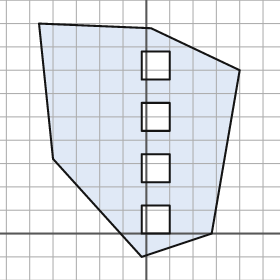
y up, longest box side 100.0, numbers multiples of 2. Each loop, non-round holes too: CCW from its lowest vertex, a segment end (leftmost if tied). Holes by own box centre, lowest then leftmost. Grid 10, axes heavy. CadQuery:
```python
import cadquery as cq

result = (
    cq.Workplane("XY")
    .moveTo(-2.0, -10.0)
    .lineTo(28.0, 0.0)
    .lineTo(40.0, 70.0)
    .lineTo(2.0, 88.0)
    .lineTo(-46.0, 90.0)
    .lineTo(-40.0, 32.0)
    .close()
    .moveTo(-2.0, 0.0)
    .lineTo(10.0, 0.0)
    .lineTo(10.0, 12.0)
    .lineTo(-2.0, 12.0)
    .close()
    .moveTo(-2.0, 22.0)
    .lineTo(10.0, 22.0)
    .lineTo(10.0, 34.0)
    .lineTo(-2.0, 34.0)
    .close()
    .moveTo(-2.0, 44.0)
    .lineTo(10.0, 44.0)
    .lineTo(10.0, 56.0)
    .lineTo(-2.0, 56.0)
    .close()
    .moveTo(-2.0, 66.0)
    .lineTo(10.0, 66.0)
    .lineTo(10.0, 78.0)
    .lineTo(-2.0, 78.0)
    .close()
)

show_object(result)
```